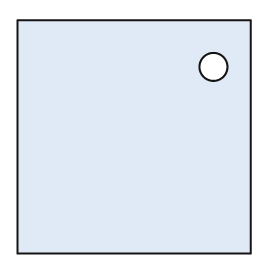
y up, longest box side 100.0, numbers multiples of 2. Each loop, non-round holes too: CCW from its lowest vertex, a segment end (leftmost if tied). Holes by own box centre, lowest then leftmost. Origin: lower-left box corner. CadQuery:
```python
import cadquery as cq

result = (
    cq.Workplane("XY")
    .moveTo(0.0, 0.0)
    .lineTo(100.0, 0.0)
    .lineTo(100.0, 100.0)
    .lineTo(0.0, 100.0)
    .close()
    .moveTo(84.0, 80.0)
    .circle(6.0)
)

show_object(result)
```